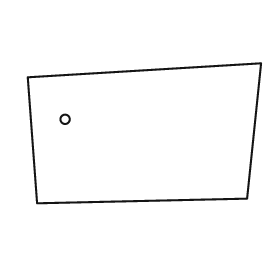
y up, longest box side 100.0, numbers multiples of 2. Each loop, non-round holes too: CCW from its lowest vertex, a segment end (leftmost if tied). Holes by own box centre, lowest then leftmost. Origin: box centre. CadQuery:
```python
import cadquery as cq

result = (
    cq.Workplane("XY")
    .moveTo(-46.0, -30.0)
    .lineTo(44.0, -28.0)
    .lineTo(50.0, 30.0)
    .lineTo(-50.0, 24.0)
    .close()
    .moveTo(-34.0, 6.0)
    .circle(2.0)
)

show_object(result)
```